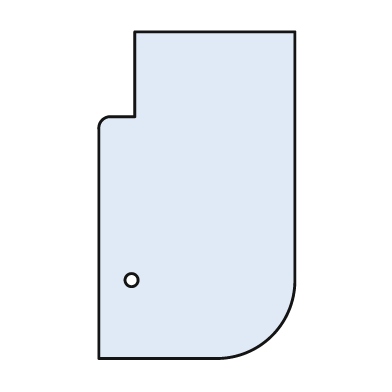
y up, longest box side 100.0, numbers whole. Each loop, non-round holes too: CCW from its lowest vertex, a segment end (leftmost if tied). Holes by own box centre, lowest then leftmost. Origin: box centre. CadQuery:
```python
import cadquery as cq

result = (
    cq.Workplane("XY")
    .moveTo(-30.0, -50.0)
    .lineTo(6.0, -50.0)
    .threePointArc((23.0, -43.0), (30.0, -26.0))
    .lineTo(30.0, 50.0)
    .lineTo(-19.0, 50.0)
    .lineTo(-19.0, 24.0)
    .lineTo(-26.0, 24.0)
    .threePointArc((-29.0, 23.0), (-30.0, 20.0))
    .close()
    .moveTo(-20.0, -26.0)
    .circle(2.0)
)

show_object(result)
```